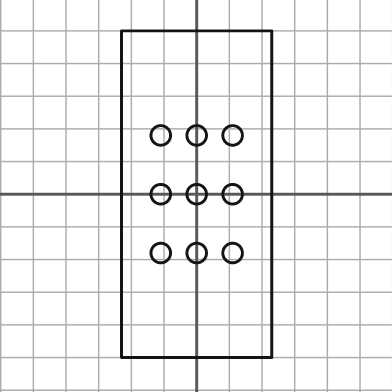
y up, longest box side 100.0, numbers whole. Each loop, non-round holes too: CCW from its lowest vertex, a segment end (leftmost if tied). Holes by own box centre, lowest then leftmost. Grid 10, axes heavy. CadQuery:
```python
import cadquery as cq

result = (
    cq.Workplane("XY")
    .moveTo(-23.0, -50.0)
    .lineTo(23.0, -50.0)
    .lineTo(23.0, 50.0)
    .lineTo(-23.0, 50.0)
    .close()
    .moveTo(-11.0, -18.0)
    .circle(3.0)
    .moveTo(0.0, -18.0)
    .circle(3.0)
    .moveTo(11.0, -18.0)
    .circle(3.0)
    .moveTo(-11.0, 0.0)
    .circle(3.0)
    .moveTo(0.0, 0.0)
    .circle(3.0)
    .moveTo(11.0, 0.0)
    .circle(3.0)
    .moveTo(-11.0, 18.0)
    .circle(3.0)
    .moveTo(0.0, 18.0)
    .circle(3.0)
    .moveTo(11.0, 18.0)
    .circle(3.0)
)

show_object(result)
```